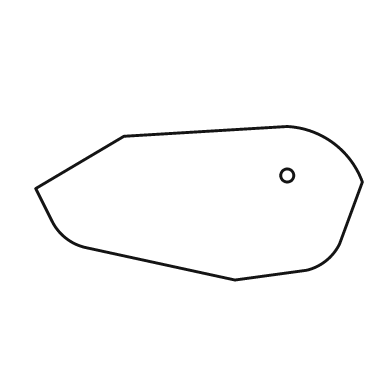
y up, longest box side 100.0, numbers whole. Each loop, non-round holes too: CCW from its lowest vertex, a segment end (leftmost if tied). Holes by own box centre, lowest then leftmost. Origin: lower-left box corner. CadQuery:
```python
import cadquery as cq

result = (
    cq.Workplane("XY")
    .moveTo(61.0, 0.0)
    .lineTo(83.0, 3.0)
    .threePointArc((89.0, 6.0), (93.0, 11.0))
    .lineTo(100.0, 30.0)
    .threePointArc((91.0, 42.0), (77.0, 47.0))
    .lineTo(27.0, 44.0)
    .lineTo(0.0, 28.0)
    .lineTo(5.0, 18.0)
    .threePointArc((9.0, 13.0), (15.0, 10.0))
    .close()
    .moveTo(77.0, 32.0)
    .circle(2.0)
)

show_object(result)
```